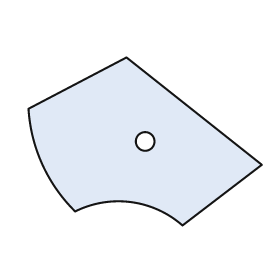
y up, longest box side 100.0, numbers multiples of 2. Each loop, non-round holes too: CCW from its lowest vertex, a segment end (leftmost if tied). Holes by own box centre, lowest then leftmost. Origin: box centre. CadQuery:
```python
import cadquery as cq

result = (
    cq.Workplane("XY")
    .moveTo(16.0, -36.0)
    .lineTo(50.0, -10.0)
    .lineTo(-8.0, 36.0)
    .lineTo(-50.0, 14.0)
    .threePointArc((-44.0, -10.0), (-30.0, -30.0))
    .threePointArc((-6.0, -26.0), (16.0, -36.0))
    .close()
    .moveTo(0.0, 0.0)
    .circle(4.0)
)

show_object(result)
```